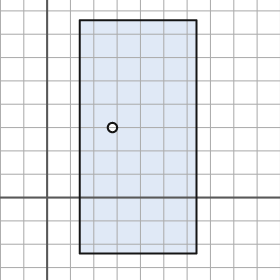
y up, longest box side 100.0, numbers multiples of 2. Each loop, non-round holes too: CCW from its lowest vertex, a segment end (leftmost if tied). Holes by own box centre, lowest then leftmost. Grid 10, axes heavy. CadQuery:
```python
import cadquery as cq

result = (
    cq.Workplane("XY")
    .moveTo(14.0, -24.0)
    .lineTo(64.0, -24.0)
    .lineTo(64.0, 76.0)
    .lineTo(14.0, 76.0)
    .close()
    .moveTo(28.0, 30.0)
    .circle(2.0)
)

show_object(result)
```